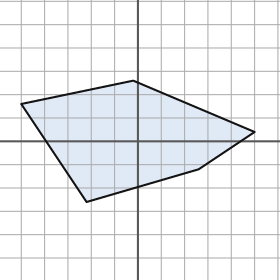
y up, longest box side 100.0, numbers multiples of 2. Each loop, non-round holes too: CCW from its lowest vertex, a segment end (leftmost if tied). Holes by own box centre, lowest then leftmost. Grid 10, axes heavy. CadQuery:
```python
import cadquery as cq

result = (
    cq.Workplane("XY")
    .moveTo(-22.0, -26.0)
    .lineTo(26.0, -12.0)
    .lineTo(50.0, 4.0)
    .lineTo(-2.0, 26.0)
    .lineTo(-50.0, 16.0)
    .close()
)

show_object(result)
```